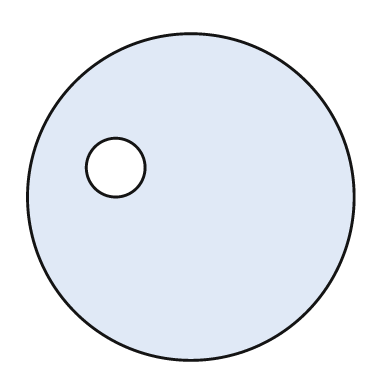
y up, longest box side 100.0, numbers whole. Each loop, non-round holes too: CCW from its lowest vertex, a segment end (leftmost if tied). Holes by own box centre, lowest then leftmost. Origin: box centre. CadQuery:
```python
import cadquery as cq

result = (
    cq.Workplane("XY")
    .moveTo(0.0, 0.0)
    .circle(50.0)
    .moveTo(-23.0, 9.0)
    .circle(9.0)
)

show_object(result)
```